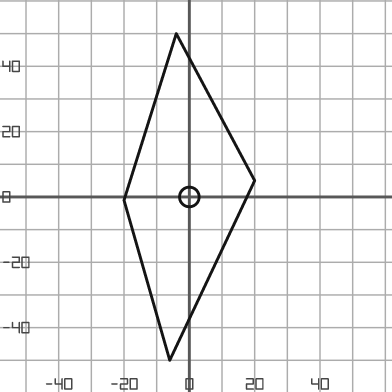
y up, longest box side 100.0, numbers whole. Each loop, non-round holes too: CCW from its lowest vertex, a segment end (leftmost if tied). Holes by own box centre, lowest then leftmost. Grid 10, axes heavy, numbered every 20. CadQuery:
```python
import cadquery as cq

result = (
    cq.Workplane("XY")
    .moveTo(-6.0, -50.0)
    .lineTo(20.0, 5.0)
    .lineTo(-4.0, 50.0)
    .lineTo(-20.0, -1.0)
    .close()
    .moveTo(0.0, 0.0)
    .circle(3.0)
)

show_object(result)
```